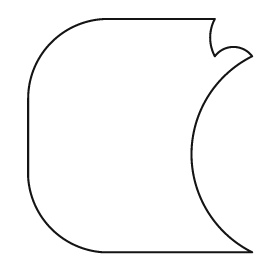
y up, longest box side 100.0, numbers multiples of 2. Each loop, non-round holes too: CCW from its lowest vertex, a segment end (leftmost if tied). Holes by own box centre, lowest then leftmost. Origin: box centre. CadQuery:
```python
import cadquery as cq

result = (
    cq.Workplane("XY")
    .moveTo(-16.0, -50.0)
    .lineTo(48.0, -50.0)
    .threePointArc((22.0, -8.0), (48.0, 34.0))
    .threePointArc((40.0, 38.0), (32.0, 34.0))
    .threePointArc((30.0, 42.0), (32.0, 50.0))
    .lineTo(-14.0, 50.0)
    .threePointArc((-38.0, 40.0), (-48.0, 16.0))
    .lineTo(-48.0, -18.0)
    .threePointArc((-38.0, -40.0), (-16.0, -50.0))
    .close()
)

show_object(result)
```